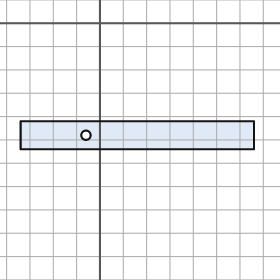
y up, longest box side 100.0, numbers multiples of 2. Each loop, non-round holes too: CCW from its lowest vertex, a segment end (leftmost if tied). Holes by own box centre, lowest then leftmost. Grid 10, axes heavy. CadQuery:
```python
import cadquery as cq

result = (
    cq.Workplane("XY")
    .moveTo(-34.0, -54.0)
    .lineTo(66.0, -54.0)
    .lineTo(66.0, -42.0)
    .lineTo(-34.0, -42.0)
    .close()
    .moveTo(-6.0, -48.0)
    .circle(2.0)
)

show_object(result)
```